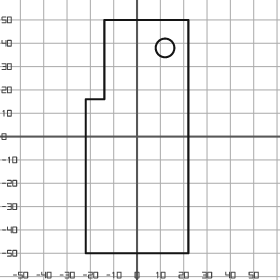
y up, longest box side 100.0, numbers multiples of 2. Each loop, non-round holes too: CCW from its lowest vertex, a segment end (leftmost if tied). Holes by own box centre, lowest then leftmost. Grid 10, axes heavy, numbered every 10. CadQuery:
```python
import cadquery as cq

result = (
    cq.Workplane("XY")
    .moveTo(-22.0, -50.0)
    .lineTo(22.0, -50.0)
    .lineTo(22.0, 50.0)
    .lineTo(-14.0, 50.0)
    .lineTo(-14.0, 16.0)
    .lineTo(-22.0, 16.0)
    .close()
    .moveTo(12.0, 38.0)
    .circle(4.0)
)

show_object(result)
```